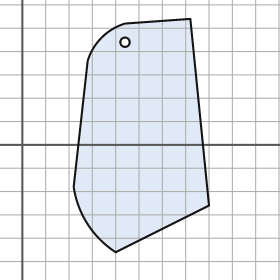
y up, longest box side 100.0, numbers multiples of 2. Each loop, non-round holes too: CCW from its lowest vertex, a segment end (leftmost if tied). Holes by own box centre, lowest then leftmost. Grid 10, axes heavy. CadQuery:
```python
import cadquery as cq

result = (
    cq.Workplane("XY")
    .moveTo(40.0, -46.0)
    .lineTo(80.0, -26.0)
    .lineTo(72.0, 54.0)
    .lineTo(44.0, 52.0)
    .threePointArc((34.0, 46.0), (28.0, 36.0))
    .lineTo(22.0, -18.0)
    .threePointArc((28.0, -34.0), (40.0, -46.0))
    .close()
    .moveTo(44.0, 44.0)
    .circle(2.0)
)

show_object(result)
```